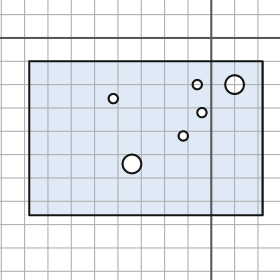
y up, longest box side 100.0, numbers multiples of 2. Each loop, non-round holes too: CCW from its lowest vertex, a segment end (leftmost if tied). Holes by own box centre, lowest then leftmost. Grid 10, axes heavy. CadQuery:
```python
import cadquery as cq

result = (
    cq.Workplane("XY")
    .moveTo(-78.0, -76.0)
    .lineTo(22.0, -76.0)
    .lineTo(22.0, -10.0)
    .lineTo(-78.0, -10.0)
    .close()
    .moveTo(-34.0, -54.0)
    .circle(4.0)
    .moveTo(-12.0, -42.0)
    .circle(2.0)
    .moveTo(-4.0, -32.0)
    .circle(2.0)
    .moveTo(-42.0, -26.0)
    .circle(2.0)
    .moveTo(-6.0, -20.0)
    .circle(2.0)
    .moveTo(10.0, -20.0)
    .circle(4.0)
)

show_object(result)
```